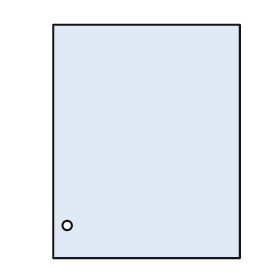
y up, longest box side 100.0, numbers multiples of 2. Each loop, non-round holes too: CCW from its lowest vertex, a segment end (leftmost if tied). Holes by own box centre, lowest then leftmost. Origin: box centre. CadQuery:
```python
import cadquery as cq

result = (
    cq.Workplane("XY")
    .moveTo(-40.0, -50.0)
    .lineTo(40.0, -50.0)
    .lineTo(40.0, 50.0)
    .lineTo(-40.0, 50.0)
    .close()
    .moveTo(-34.0, -36.0)
    .circle(2.0)
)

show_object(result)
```